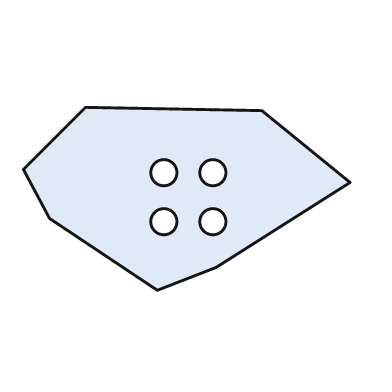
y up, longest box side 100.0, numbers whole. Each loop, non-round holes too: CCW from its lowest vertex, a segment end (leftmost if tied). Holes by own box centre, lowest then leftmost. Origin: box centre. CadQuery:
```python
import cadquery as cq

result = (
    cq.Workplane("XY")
    .moveTo(-9.0, -28.0)
    .lineTo(9.0, -21.0)
    .lineTo(50.0, 5.0)
    .lineTo(23.0, 27.0)
    .lineTo(-31.0, 28.0)
    .lineTo(-50.0, 9.0)
    .lineTo(-42.0, -6.0)
    .close()
    .moveTo(-7.0, -7.0)
    .circle(4.0)
    .moveTo(8.0, -7.0)
    .circle(4.0)
    .moveTo(-7.0, 8.0)
    .circle(4.0)
    .moveTo(8.0, 8.0)
    .circle(4.0)
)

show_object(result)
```